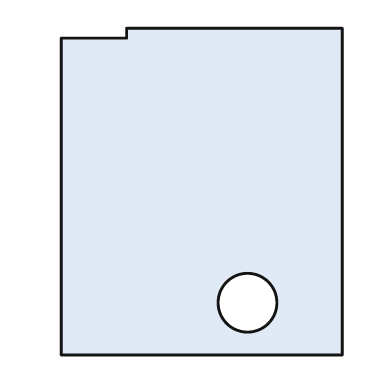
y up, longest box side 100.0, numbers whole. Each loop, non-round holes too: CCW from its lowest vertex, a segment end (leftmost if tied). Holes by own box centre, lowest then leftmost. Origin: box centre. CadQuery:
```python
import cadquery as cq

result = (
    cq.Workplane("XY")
    .moveTo(-43.0, -50.0)
    .lineTo(43.0, -50.0)
    .lineTo(43.0, 50.0)
    .lineTo(-23.0, 50.0)
    .lineTo(-23.0, 47.0)
    .lineTo(-43.0, 47.0)
    .close()
    .moveTo(14.0, -34.0)
    .circle(9.0)
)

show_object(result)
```